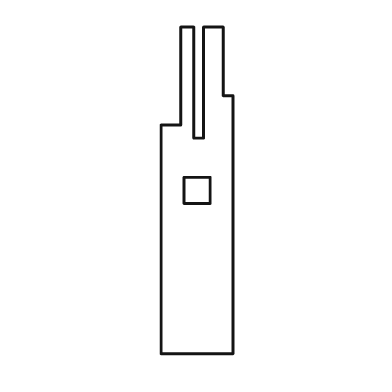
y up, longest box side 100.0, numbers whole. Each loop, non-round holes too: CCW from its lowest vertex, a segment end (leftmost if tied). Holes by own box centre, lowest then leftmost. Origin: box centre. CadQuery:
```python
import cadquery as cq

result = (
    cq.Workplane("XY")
    .moveTo(-11.0, -50.0)
    .lineTo(11.0, -50.0)
    .lineTo(11.0, 29.0)
    .lineTo(8.0, 29.0)
    .lineTo(8.0, 50.0)
    .lineTo(2.0, 50.0)
    .lineTo(2.0, 16.0)
    .lineTo(-1.0, 16.0)
    .lineTo(-1.0, 50.0)
    .lineTo(-5.0, 50.0)
    .lineTo(-5.0, 20.0)
    .lineTo(-11.0, 20.0)
    .close()
    .moveTo(-4.0, -4.0)
    .lineTo(4.0, -4.0)
    .lineTo(4.0, 4.0)
    .lineTo(-4.0, 4.0)
    .close()
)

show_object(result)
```